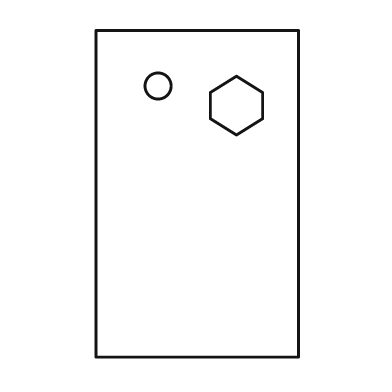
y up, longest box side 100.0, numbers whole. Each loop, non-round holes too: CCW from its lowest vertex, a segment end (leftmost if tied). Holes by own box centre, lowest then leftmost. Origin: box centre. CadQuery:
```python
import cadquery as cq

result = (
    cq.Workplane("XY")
    .moveTo(-31.0, -50.0)
    .lineTo(31.0, -50.0)
    .lineTo(31.0, 50.0)
    .lineTo(-31.0, 50.0)
    .close()
    .moveTo(12.0, 18.0)
    .lineTo(20.0, 23.0)
    .lineTo(20.0, 31.0)
    .lineTo(12.0, 36.0)
    .lineTo(4.0, 31.0)
    .lineTo(4.0, 23.0)
    .close()
    .moveTo(-12.0, 33.0)
    .circle(4.0)
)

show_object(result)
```